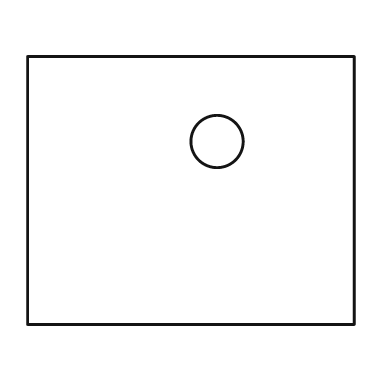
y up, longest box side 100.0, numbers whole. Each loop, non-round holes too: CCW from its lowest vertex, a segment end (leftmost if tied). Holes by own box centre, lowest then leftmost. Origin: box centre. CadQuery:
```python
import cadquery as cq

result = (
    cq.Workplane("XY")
    .moveTo(-50.0, -41.0)
    .lineTo(50.0, -41.0)
    .lineTo(50.0, 41.0)
    .lineTo(-50.0, 41.0)
    .close()
    .moveTo(8.0, 15.0)
    .circle(8.0)
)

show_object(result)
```